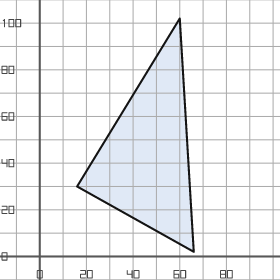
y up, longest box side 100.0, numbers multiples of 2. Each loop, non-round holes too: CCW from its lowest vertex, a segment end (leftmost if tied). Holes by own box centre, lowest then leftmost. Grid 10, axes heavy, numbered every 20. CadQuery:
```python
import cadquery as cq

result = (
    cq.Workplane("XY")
    .moveTo(66.0, 2.0)
    .lineTo(60.0, 102.0)
    .lineTo(16.0, 30.0)
    .close()
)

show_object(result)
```